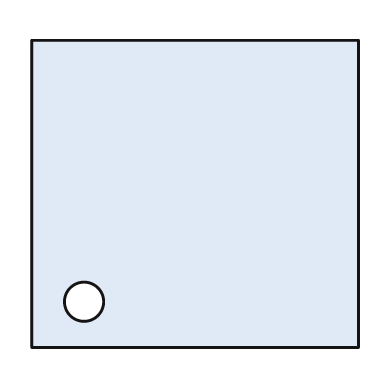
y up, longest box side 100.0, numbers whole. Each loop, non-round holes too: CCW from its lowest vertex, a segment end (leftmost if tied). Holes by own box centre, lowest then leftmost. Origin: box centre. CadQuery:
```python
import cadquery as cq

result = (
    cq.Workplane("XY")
    .moveTo(-50.0, -47.0)
    .lineTo(50.0, -47.0)
    .lineTo(50.0, 47.0)
    .lineTo(-50.0, 47.0)
    .close()
    .moveTo(-34.0, -33.0)
    .circle(6.0)
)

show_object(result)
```